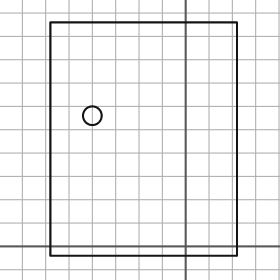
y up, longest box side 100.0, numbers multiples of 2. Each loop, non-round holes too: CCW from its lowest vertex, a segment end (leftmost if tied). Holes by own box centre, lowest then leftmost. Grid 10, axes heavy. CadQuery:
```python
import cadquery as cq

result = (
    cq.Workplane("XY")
    .moveTo(-58.0, -4.0)
    .lineTo(22.0, -4.0)
    .lineTo(22.0, 96.0)
    .lineTo(-58.0, 96.0)
    .close()
    .moveTo(-40.0, 56.0)
    .circle(4.0)
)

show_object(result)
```